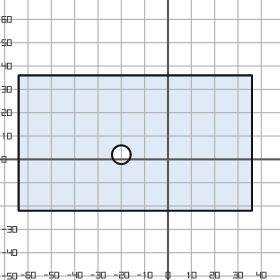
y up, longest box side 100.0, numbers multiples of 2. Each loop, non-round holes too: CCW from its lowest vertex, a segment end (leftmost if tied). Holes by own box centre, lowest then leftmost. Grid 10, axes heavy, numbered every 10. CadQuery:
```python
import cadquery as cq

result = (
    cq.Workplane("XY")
    .moveTo(-64.0, -22.0)
    .lineTo(36.0, -22.0)
    .lineTo(36.0, 36.0)
    .lineTo(-64.0, 36.0)
    .close()
    .moveTo(-20.0, 2.0)
    .circle(4.0)
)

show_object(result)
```